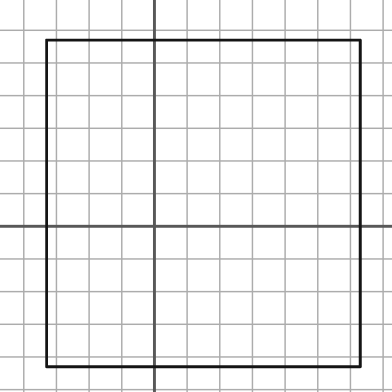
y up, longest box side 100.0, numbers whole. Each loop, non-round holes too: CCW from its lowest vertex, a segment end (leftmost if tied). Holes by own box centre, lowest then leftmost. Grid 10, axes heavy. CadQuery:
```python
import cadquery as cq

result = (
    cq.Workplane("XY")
    .moveTo(-33.0, -43.0)
    .lineTo(63.0, -43.0)
    .lineTo(63.0, 57.0)
    .lineTo(-33.0, 57.0)
    .close()
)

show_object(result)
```